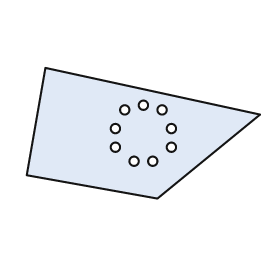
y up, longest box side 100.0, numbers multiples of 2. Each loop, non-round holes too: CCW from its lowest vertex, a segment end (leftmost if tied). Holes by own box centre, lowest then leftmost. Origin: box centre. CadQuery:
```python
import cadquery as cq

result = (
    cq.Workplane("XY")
    .moveTo(6.0, -28.0)
    .lineTo(50.0, 8.0)
    .lineTo(-42.0, 28.0)
    .lineTo(-50.0, -18.0)
    .close()
    .moveTo(-4.0, -12.0)
    .circle(2.0)
    .moveTo(4.0, -12.0)
    .circle(2.0)
    .moveTo(-12.0, -6.0)
    .circle(2.0)
    .moveTo(12.0, -6.0)
    .circle(2.0)
    .moveTo(-12.0, 2.0)
    .circle(2.0)
    .moveTo(12.0, 2.0)
    .circle(2.0)
    .moveTo(-8.0, 10.0)
    .circle(2.0)
    .moveTo(8.0, 10.0)
    .circle(2.0)
    .moveTo(0.0, 12.0)
    .circle(2.0)
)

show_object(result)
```